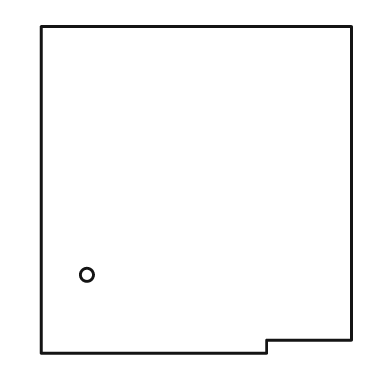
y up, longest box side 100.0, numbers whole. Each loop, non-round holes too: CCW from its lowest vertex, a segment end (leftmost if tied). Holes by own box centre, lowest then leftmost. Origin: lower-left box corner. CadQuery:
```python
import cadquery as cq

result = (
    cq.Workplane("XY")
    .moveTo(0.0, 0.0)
    .lineTo(69.0, 0.0)
    .lineTo(69.0, 4.0)
    .lineTo(95.0, 4.0)
    .lineTo(95.0, 100.0)
    .lineTo(0.0, 100.0)
    .close()
    .moveTo(14.0, 24.0)
    .circle(2.0)
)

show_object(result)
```